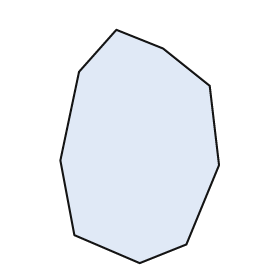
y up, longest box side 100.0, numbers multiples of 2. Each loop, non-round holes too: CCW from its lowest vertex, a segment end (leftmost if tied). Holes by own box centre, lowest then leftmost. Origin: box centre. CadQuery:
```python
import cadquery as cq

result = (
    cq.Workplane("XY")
    .moveTo(0.0, -50.0)
    .lineTo(20.0, -42.0)
    .lineTo(34.0, -8.0)
    .lineTo(30.0, 26.0)
    .lineTo(10.0, 42.0)
    .lineTo(-10.0, 50.0)
    .lineTo(-26.0, 32.0)
    .lineTo(-34.0, -6.0)
    .lineTo(-28.0, -38.0)
    .close()
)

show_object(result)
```